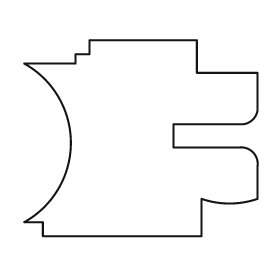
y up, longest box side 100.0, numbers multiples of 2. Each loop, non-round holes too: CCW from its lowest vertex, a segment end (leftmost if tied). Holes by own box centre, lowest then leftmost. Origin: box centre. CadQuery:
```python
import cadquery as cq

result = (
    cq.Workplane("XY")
    .moveTo(-42.0, -42.0)
    .lineTo(26.0, -42.0)
    .lineTo(26.0, -26.0)
    .threePointArc((38.0, -28.0), (50.0, -26.0))
    .lineTo(50.0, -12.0)
    .threePointArc((48.0, -6.0), (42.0, -4.0))
    .lineTo(14.0, -4.0)
    .lineTo(14.0, 6.0)
    .lineTo(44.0, 6.0)
    .threePointArc((48.0, 8.0), (50.0, 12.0))
    .lineTo(50.0, 28.0)
    .lineTo(24.0, 28.0)
    .lineTo(24.0, 42.0)
    .lineTo(-22.0, 42.0)
    .lineTo(-22.0, 36.0)
    .lineTo(-28.0, 36.0)
    .lineTo(-28.0, 32.0)
    .lineTo(-50.0, 32.0)
    .threePointArc((-30.0, -2.0), (-50.0, -36.0))
    .lineTo(-42.0, -36.0)
    .close()
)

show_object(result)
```